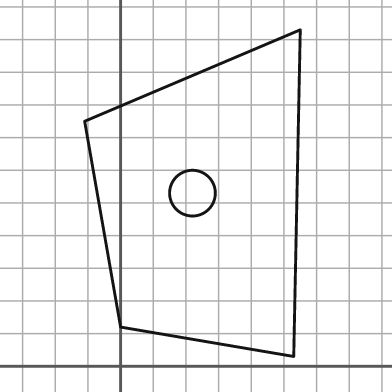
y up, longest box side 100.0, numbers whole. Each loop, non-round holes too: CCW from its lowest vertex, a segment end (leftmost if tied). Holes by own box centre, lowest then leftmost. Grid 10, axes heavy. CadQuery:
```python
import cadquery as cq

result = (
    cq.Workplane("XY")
    .moveTo(53.0, 3.0)
    .lineTo(55.0, 103.0)
    .lineTo(-11.0, 75.0)
    .lineTo(0.0, 12.0)
    .close()
    .moveTo(22.0, 53.0)
    .circle(7.0)
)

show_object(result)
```